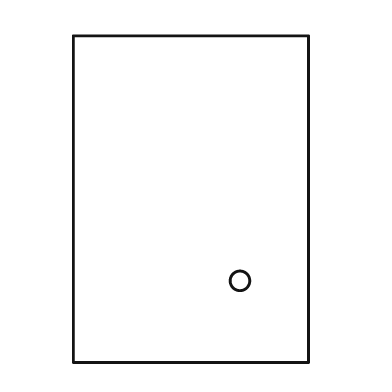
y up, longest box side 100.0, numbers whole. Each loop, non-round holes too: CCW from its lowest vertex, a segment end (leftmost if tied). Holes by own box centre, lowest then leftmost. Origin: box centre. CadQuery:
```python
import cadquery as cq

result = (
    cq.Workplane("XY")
    .moveTo(-36.0, -50.0)
    .lineTo(36.0, -50.0)
    .lineTo(36.0, 50.0)
    .lineTo(-36.0, 50.0)
    .close()
    .moveTo(15.0, -25.0)
    .circle(3.0)
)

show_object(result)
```